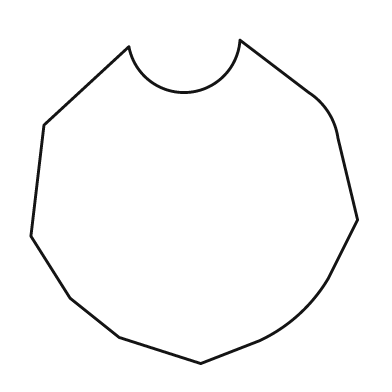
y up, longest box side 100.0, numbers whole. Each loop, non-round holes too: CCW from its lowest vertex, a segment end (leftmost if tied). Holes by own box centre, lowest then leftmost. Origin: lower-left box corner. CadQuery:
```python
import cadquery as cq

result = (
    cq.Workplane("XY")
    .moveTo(52.0, 0.0)
    .lineTo(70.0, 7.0)
    .threePointArc((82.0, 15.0), (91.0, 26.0))
    .lineTo(100.0, 44.0)
    .lineTo(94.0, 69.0)
    .threePointArc((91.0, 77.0), (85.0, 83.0))
    .lineTo(64.0, 99.0)
    .threePointArc((48.0, 83.0), (30.0, 97.0))
    .lineTo(4.0, 73.0)
    .lineTo(0.0, 39.0)
    .lineTo(12.0, 20.0)
    .lineTo(27.0, 8.0)
    .close()
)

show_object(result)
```